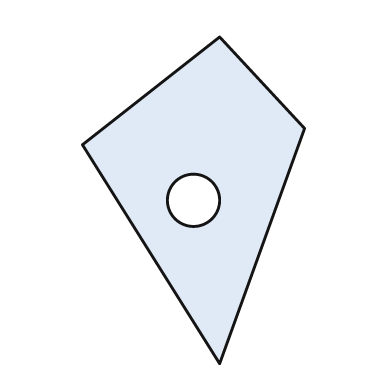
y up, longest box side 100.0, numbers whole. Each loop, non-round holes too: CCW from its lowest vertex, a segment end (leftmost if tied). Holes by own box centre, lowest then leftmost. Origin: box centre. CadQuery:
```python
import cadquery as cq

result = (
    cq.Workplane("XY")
    .moveTo(8.0, -50.0)
    .lineTo(34.0, 22.0)
    .lineTo(8.0, 50.0)
    .lineTo(-34.0, 17.0)
    .close()
    .moveTo(0.0, 0.0)
    .circle(8.0)
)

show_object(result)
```